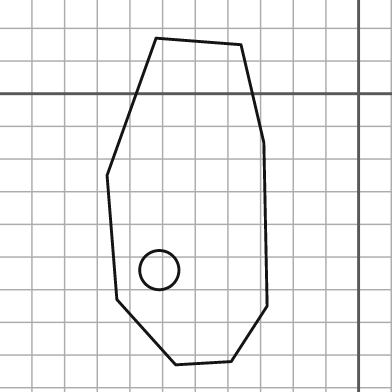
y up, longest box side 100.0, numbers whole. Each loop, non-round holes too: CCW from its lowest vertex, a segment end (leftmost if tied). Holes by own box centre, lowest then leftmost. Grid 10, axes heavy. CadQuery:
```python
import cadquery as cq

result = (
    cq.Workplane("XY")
    .moveTo(-56.0, -83.0)
    .lineTo(-39.0, -82.0)
    .lineTo(-28.0, -65.0)
    .lineTo(-29.0, -15.0)
    .lineTo(-36.0, 15.0)
    .lineTo(-62.0, 17.0)
    .lineTo(-77.0, -25.0)
    .lineTo(-74.0, -63.0)
    .close()
    .moveTo(-61.0, -54.0)
    .circle(6.0)
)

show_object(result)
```